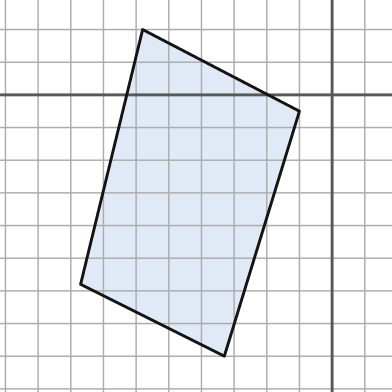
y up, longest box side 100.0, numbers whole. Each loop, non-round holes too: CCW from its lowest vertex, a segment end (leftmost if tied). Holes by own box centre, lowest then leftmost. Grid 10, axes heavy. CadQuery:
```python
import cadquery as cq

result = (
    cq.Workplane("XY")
    .moveTo(-33.0, -80.0)
    .lineTo(-10.0, -5.0)
    .lineTo(-58.0, 20.0)
    .lineTo(-77.0, -58.0)
    .close()
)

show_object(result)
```